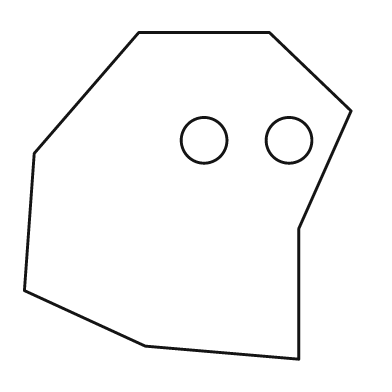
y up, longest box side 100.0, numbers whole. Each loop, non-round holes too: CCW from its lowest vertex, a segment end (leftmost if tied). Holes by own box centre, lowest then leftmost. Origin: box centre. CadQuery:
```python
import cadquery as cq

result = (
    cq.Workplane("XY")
    .moveTo(34.0, -50.0)
    .lineTo(34.0, -10.0)
    .lineTo(50.0, 26.0)
    .lineTo(25.0, 50.0)
    .lineTo(-15.0, 50.0)
    .lineTo(-47.0, 13.0)
    .lineTo(-50.0, -29.0)
    .lineTo(-13.0, -46.0)
    .close()
    .moveTo(5.0, 17.0)
    .circle(7.0)
    .moveTo(31.0, 17.0)
    .circle(7.0)
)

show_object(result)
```